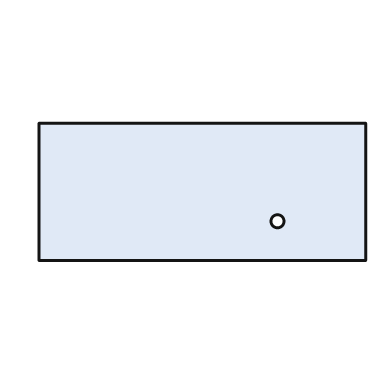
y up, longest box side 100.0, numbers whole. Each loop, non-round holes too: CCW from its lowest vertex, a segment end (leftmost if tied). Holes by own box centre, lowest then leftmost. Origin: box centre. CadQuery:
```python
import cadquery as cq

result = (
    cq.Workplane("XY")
    .moveTo(-50.0, -21.0)
    .lineTo(50.0, -21.0)
    .lineTo(50.0, 21.0)
    .lineTo(-50.0, 21.0)
    .close()
    .moveTo(23.0, -9.0)
    .circle(2.0)
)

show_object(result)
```